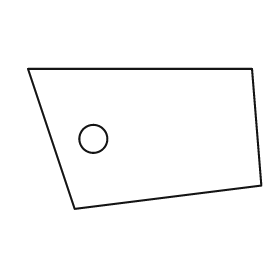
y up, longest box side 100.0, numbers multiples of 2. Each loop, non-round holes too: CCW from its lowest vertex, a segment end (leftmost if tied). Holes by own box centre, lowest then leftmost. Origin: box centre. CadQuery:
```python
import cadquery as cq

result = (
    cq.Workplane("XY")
    .moveTo(-30.0, -30.0)
    .lineTo(50.0, -20.0)
    .lineTo(46.0, 30.0)
    .lineTo(-50.0, 30.0)
    .close()
    .moveTo(-22.0, 0.0)
    .circle(6.0)
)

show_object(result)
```